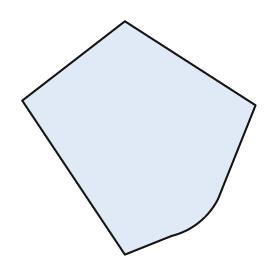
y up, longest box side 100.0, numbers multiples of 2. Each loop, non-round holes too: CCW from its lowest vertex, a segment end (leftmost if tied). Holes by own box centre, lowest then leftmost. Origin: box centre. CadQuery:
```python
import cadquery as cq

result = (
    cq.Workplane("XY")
    .moveTo(-6.0, -50.0)
    .lineTo(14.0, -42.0)
    .threePointArc((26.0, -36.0), (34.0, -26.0))
    .lineTo(50.0, 14.0)
    .lineTo(-6.0, 50.0)
    .lineTo(-50.0, 16.0)
    .close()
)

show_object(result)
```